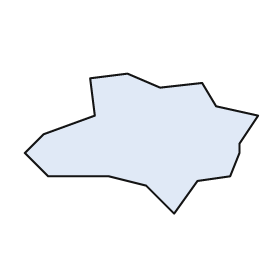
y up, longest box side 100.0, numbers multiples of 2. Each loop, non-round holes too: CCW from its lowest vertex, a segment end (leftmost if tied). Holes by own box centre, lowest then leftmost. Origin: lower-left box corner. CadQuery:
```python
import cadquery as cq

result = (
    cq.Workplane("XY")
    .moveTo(64.0, 0.0)
    .lineTo(74.0, 14.0)
    .lineTo(88.0, 16.0)
    .lineTo(92.0, 26.0)
    .lineTo(92.0, 30.0)
    .lineTo(100.0, 42.0)
    .lineTo(82.0, 46.0)
    .lineTo(76.0, 56.0)
    .lineTo(58.0, 54.0)
    .lineTo(44.0, 60.0)
    .lineTo(28.0, 58.0)
    .lineTo(30.0, 42.0)
    .lineTo(8.0, 34.0)
    .lineTo(0.0, 26.0)
    .lineTo(10.0, 16.0)
    .lineTo(36.0, 16.0)
    .lineTo(52.0, 12.0)
    .close()
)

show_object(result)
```